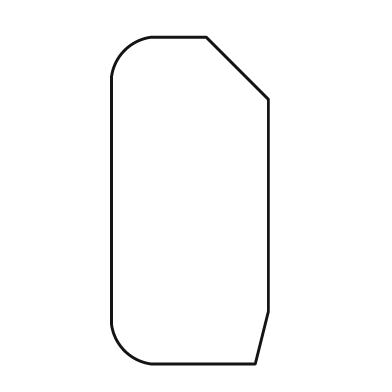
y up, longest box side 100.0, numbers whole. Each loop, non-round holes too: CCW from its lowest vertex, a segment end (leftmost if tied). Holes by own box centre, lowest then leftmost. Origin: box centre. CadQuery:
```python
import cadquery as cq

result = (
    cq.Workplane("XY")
    .moveTo(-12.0, -50.0)
    .lineTo(20.0, -50.0)
    .lineTo(24.0, -34.0)
    .lineTo(24.0, 31.0)
    .lineTo(5.0, 50.0)
    .lineTo(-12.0, 50.0)
    .threePointArc((-20.0, 46.0), (-24.0, 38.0))
    .lineTo(-24.0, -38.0)
    .threePointArc((-20.0, -46.0), (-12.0, -50.0))
    .close()
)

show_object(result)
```